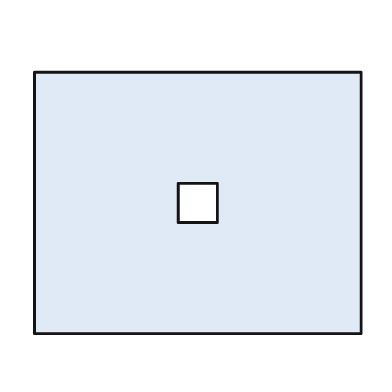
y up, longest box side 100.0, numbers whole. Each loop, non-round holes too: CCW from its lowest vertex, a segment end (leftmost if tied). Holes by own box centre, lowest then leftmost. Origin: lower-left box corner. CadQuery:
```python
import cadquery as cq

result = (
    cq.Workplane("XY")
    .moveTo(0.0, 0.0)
    .lineTo(100.0, 0.0)
    .lineTo(100.0, 80.0)
    .lineTo(0.0, 80.0)
    .close()
    .moveTo(44.0, 34.0)
    .lineTo(56.0, 34.0)
    .lineTo(56.0, 46.0)
    .lineTo(44.0, 46.0)
    .close()
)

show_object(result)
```